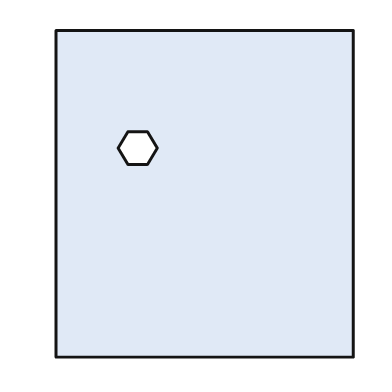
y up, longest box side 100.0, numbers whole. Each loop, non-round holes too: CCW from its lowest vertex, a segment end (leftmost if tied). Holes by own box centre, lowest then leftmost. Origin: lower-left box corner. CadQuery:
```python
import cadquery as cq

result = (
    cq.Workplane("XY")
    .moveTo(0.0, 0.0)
    .lineTo(91.0, 0.0)
    .lineTo(91.0, 100.0)
    .lineTo(0.0, 100.0)
    .close()
    .moveTo(22.0, 59.0)
    .lineTo(28.0, 59.0)
    .lineTo(31.0, 64.0)
    .lineTo(28.0, 69.0)
    .lineTo(22.0, 69.0)
    .lineTo(19.0, 64.0)
    .close()
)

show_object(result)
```